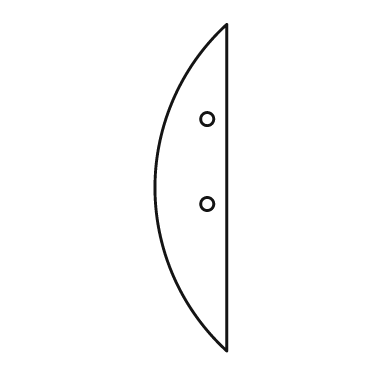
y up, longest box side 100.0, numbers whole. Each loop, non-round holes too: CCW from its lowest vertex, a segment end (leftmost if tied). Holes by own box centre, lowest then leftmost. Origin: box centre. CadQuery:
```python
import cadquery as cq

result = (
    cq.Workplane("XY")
    .moveTo(11.0, -50.0)
    .lineTo(11.0, 50.0)
    .threePointArc((-11.0, 0.0), (11.0, -50.0))
    .close()
    .moveTo(5.0, -5.0)
    .circle(2.0)
    .moveTo(5.0, 21.0)
    .circle(2.0)
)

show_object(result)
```